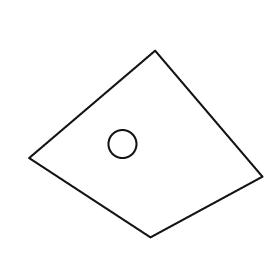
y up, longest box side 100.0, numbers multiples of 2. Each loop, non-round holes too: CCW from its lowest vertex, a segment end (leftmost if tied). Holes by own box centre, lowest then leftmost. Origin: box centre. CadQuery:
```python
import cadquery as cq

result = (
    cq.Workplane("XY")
    .moveTo(2.0, -40.0)
    .lineTo(50.0, -14.0)
    .lineTo(4.0, 40.0)
    .lineTo(-50.0, -6.0)
    .close()
    .moveTo(-10.0, 0.0)
    .circle(6.0)
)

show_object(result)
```